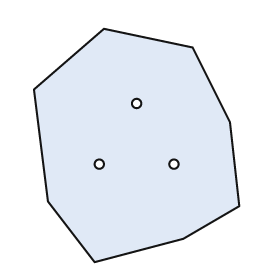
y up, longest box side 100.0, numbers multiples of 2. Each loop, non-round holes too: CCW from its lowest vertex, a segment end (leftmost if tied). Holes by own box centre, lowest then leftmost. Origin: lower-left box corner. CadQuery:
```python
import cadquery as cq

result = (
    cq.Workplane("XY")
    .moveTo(26.0, 0.0)
    .lineTo(64.0, 10.0)
    .lineTo(88.0, 24.0)
    .lineTo(84.0, 60.0)
    .lineTo(68.0, 92.0)
    .lineTo(30.0, 100.0)
    .lineTo(0.0, 74.0)
    .lineTo(6.0, 26.0)
    .close()
    .moveTo(28.0, 42.0)
    .circle(2.0)
    .moveTo(60.0, 42.0)
    .circle(2.0)
    .moveTo(44.0, 68.0)
    .circle(2.0)
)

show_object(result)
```